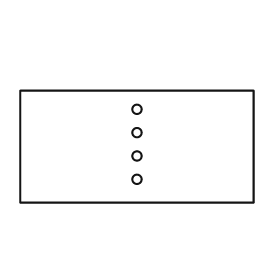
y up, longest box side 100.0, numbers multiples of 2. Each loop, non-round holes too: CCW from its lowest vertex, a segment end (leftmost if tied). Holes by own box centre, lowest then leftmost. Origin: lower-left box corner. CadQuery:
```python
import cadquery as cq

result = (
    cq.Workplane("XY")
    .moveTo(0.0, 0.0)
    .lineTo(100.0, 0.0)
    .lineTo(100.0, 48.0)
    .lineTo(0.0, 48.0)
    .close()
    .moveTo(50.0, 10.0)
    .circle(2.0)
    .moveTo(50.0, 20.0)
    .circle(2.0)
    .moveTo(50.0, 30.0)
    .circle(2.0)
    .moveTo(50.0, 40.0)
    .circle(2.0)
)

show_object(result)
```